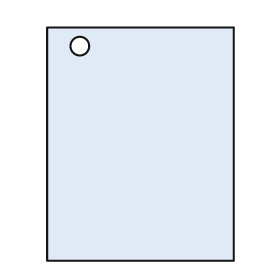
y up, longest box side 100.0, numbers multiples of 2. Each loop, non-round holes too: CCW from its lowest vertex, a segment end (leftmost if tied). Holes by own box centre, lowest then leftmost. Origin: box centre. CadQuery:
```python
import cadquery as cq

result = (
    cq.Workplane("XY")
    .moveTo(-40.0, -50.0)
    .lineTo(40.0, -50.0)
    .lineTo(40.0, 50.0)
    .lineTo(-40.0, 50.0)
    .close()
    .moveTo(-26.0, 42.0)
    .circle(4.0)
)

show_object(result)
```